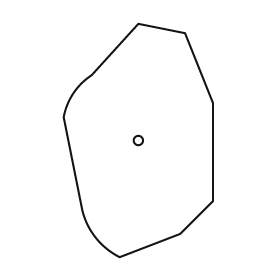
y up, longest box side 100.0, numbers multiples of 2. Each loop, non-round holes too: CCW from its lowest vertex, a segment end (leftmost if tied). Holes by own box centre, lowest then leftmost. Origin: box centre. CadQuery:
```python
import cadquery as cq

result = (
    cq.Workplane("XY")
    .moveTo(-8.0, -50.0)
    .lineTo(18.0, -40.0)
    .lineTo(32.0, -26.0)
    .lineTo(32.0, 16.0)
    .lineTo(20.0, 46.0)
    .lineTo(0.0, 50.0)
    .lineTo(-20.0, 28.0)
    .threePointArc((-28.0, 20.0), (-32.0, 10.0))
    .lineTo(-24.0, -30.0)
    .threePointArc((-18.0, -42.0), (-8.0, -50.0))
    .close()
    .moveTo(0.0, 0.0)
    .circle(2.0)
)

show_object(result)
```